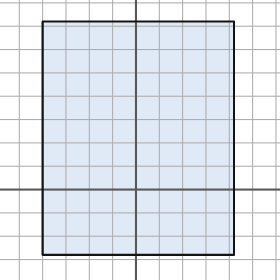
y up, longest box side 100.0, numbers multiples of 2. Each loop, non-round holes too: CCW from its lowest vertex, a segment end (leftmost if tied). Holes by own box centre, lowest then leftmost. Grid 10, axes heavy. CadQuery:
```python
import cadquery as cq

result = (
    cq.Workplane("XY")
    .moveTo(-40.0, -28.0)
    .lineTo(42.0, -28.0)
    .lineTo(42.0, 72.0)
    .lineTo(-40.0, 72.0)
    .close()
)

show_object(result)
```